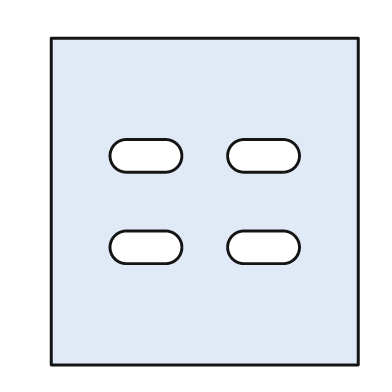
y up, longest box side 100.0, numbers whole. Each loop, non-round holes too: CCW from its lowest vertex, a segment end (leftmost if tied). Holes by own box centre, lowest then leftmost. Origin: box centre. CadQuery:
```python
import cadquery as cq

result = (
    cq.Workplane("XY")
    .moveTo(-47.0, -50.0)
    .lineTo(47.0, -50.0)
    .lineTo(47.0, 50.0)
    .lineTo(-47.0, 50.0)
    .close()
    .moveTo(-24.0, -19.0)
    .lineTo(-12.0, -19.0)
    .threePointArc((-7.0, -14.0), (-12.0, -9.0))
    .lineTo(-24.0, -9.0)
    .threePointArc((-29.0, -14.0), (-24.0, -19.0))
    .close()
    .moveTo(12.0, -19.0)
    .lineTo(24.0, -19.0)
    .threePointArc((29.0, -14.0), (24.0, -9.0))
    .lineTo(12.0, -9.0)
    .threePointArc((7.0, -14.0), (12.0, -19.0))
    .close()
    .moveTo(-24.0, 9.0)
    .lineTo(-12.0, 9.0)
    .threePointArc((-7.0, 14.0), (-12.0, 19.0))
    .lineTo(-24.0, 19.0)
    .threePointArc((-29.0, 14.0), (-24.0, 9.0))
    .close()
    .moveTo(12.0, 9.0)
    .lineTo(24.0, 9.0)
    .threePointArc((29.0, 14.0), (24.0, 19.0))
    .lineTo(12.0, 19.0)
    .threePointArc((7.0, 14.0), (12.0, 9.0))
    .close()
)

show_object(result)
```